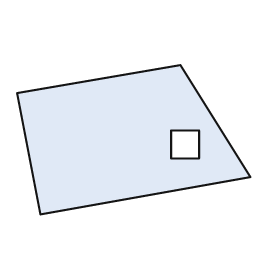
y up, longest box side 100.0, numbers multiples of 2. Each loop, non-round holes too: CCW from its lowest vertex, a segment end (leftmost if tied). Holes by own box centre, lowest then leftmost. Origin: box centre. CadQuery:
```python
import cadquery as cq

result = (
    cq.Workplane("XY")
    .moveTo(-40.0, -32.0)
    .lineTo(50.0, -16.0)
    .lineTo(20.0, 32.0)
    .lineTo(-50.0, 20.0)
    .close()
    .moveTo(16.0, -8.0)
    .lineTo(28.0, -8.0)
    .lineTo(28.0, 4.0)
    .lineTo(16.0, 4.0)
    .close()
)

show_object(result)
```